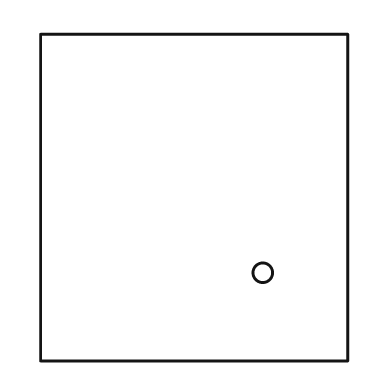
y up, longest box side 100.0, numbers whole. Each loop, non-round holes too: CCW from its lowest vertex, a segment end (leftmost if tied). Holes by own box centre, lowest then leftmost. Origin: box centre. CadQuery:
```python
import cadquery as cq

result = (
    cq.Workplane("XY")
    .moveTo(-47.0, -50.0)
    .lineTo(47.0, -50.0)
    .lineTo(47.0, 50.0)
    .lineTo(-47.0, 50.0)
    .close()
    .moveTo(21.0, -23.0)
    .circle(3.0)
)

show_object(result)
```